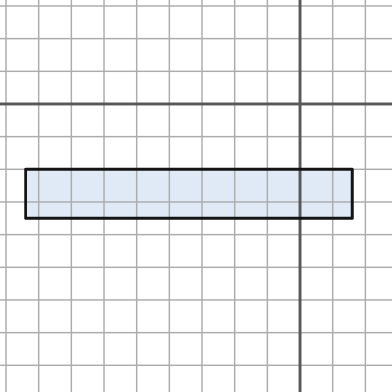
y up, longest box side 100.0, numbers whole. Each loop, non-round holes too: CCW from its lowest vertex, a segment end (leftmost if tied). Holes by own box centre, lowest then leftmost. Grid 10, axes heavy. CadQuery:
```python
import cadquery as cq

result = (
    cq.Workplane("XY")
    .moveTo(-84.0, -35.0)
    .lineTo(16.0, -35.0)
    .lineTo(16.0, -20.0)
    .lineTo(-84.0, -20.0)
    .close()
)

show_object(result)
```